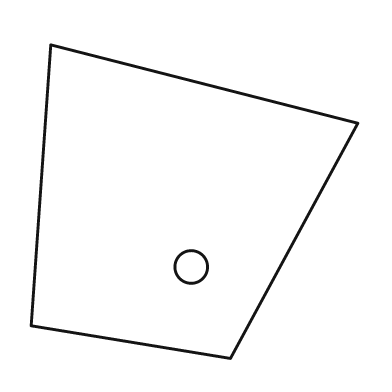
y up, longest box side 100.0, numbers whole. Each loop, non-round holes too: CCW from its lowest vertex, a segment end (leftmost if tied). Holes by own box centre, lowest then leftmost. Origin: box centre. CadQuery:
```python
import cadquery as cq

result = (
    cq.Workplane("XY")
    .moveTo(11.0, -48.0)
    .lineTo(50.0, 24.0)
    .lineTo(-44.0, 48.0)
    .lineTo(-50.0, -38.0)
    .close()
    .moveTo(-1.0, -20.0)
    .circle(5.0)
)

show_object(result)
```